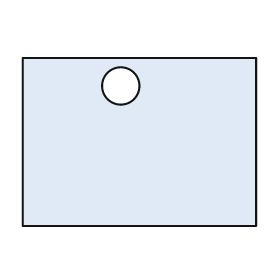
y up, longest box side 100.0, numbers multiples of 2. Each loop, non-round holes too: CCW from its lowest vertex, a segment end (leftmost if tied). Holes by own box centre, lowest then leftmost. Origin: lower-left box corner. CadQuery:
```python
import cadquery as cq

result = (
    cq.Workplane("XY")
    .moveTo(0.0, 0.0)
    .lineTo(100.0, 0.0)
    .lineTo(100.0, 72.0)
    .lineTo(0.0, 72.0)
    .close()
    .moveTo(42.0, 60.0)
    .circle(8.0)
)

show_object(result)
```